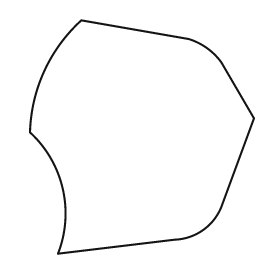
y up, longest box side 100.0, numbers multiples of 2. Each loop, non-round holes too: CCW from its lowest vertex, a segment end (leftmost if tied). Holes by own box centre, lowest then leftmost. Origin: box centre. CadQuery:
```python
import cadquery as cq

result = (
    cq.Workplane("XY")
    .moveTo(-36.0, -50.0)
    .lineTo(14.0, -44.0)
    .threePointArc((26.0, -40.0), (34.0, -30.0))
    .lineTo(48.0, 8.0)
    .lineTo(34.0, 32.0)
    .threePointArc((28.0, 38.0), (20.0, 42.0))
    .lineTo(-26.0, 50.0)
    .threePointArc((-42.0, 28.0), (-48.0, 2.0))
    .threePointArc((-34.0, -22.0), (-36.0, -50.0))
    .close()
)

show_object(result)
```